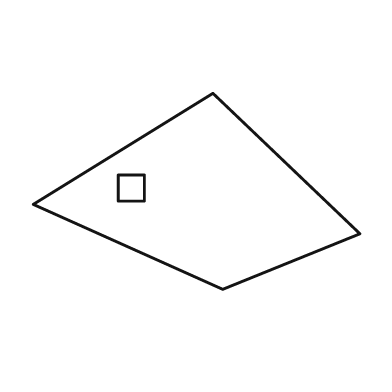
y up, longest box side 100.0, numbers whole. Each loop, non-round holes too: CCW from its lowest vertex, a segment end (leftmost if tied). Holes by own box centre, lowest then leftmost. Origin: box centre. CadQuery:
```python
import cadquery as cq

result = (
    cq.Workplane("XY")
    .moveTo(8.0, -30.0)
    .lineTo(50.0, -13.0)
    .lineTo(5.0, 30.0)
    .lineTo(-50.0, -4.0)
    .close()
    .moveTo(-24.0, -3.0)
    .lineTo(-16.0, -3.0)
    .lineTo(-16.0, 5.0)
    .lineTo(-24.0, 5.0)
    .close()
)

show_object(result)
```